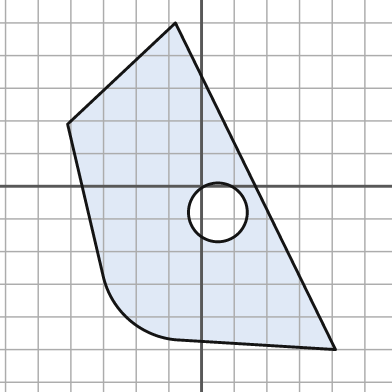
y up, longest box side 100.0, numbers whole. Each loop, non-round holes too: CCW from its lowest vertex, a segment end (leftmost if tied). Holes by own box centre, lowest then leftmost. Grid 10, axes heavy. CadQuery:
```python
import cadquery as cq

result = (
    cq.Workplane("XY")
    .moveTo(41.0, -50.0)
    .lineTo(-8.0, 50.0)
    .lineTo(-41.0, 19.0)
    .lineTo(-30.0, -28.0)
    .threePointArc((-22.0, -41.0), (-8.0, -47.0))
    .close()
    .moveTo(5.0, -8.0)
    .circle(9.0)
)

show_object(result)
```